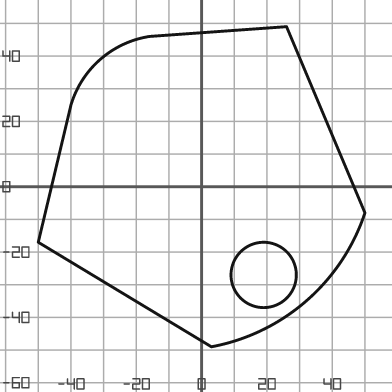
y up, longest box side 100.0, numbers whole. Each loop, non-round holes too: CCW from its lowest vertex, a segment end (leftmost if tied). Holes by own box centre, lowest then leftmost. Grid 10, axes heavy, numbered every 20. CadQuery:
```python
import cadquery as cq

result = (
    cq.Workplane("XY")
    .moveTo(3.0, -49.0)
    .threePointArc((32.0, -35.0), (50.0, -8.0))
    .lineTo(26.0, 49.0)
    .lineTo(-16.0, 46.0)
    .threePointArc((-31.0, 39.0), (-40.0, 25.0))
    .lineTo(-50.0, -17.0)
    .close()
    .moveTo(19.0, -27.0)
    .circle(10.0)
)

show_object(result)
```